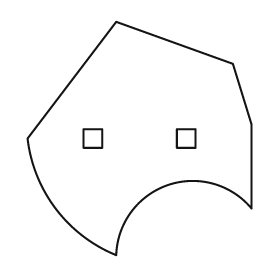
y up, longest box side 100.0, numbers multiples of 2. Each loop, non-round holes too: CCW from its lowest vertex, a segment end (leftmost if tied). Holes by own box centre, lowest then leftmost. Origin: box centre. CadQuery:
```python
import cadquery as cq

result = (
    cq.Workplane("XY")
    .moveTo(-10.0, -50.0)
    .threePointArc((12.0, -20.0), (48.0, -30.0))
    .lineTo(48.0, 6.0)
    .lineTo(40.0, 32.0)
    .lineTo(-10.0, 50.0)
    .lineTo(-48.0, 0.0)
    .threePointArc((-36.0, -30.0), (-10.0, -50.0))
    .close()
    .moveTo(-24.0, -4.0)
    .lineTo(-16.0, -4.0)
    .lineTo(-16.0, 4.0)
    .lineTo(-24.0, 4.0)
    .close()
    .moveTo(16.0, -4.0)
    .lineTo(24.0, -4.0)
    .lineTo(24.0, 4.0)
    .lineTo(16.0, 4.0)
    .close()
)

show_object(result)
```